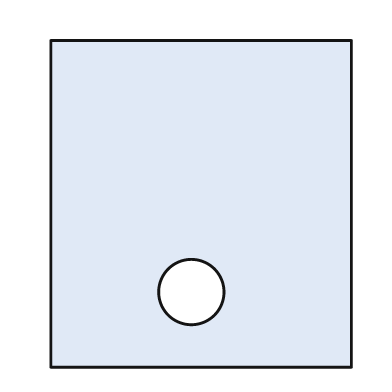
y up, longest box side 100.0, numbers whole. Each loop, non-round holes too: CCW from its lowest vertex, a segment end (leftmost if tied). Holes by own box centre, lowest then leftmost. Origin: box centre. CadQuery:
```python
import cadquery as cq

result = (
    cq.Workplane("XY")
    .moveTo(-46.0, -50.0)
    .lineTo(46.0, -50.0)
    .lineTo(46.0, 50.0)
    .lineTo(-46.0, 50.0)
    .close()
    .moveTo(-3.0, -27.0)
    .circle(10.0)
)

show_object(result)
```